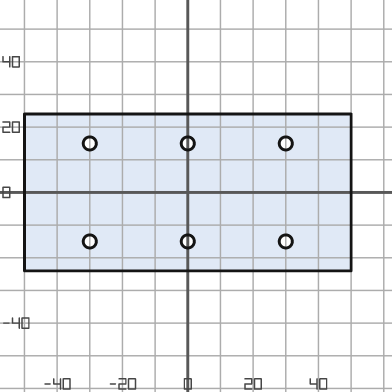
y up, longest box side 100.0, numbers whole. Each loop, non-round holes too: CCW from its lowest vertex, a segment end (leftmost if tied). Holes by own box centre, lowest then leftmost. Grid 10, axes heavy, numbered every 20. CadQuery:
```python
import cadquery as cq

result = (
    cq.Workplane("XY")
    .moveTo(-50.0, -24.0)
    .lineTo(50.0, -24.0)
    .lineTo(50.0, 24.0)
    .lineTo(-50.0, 24.0)
    .close()
    .moveTo(-30.0, -15.0)
    .circle(2.0)
    .moveTo(0.0, -15.0)
    .circle(2.0)
    .moveTo(30.0, -15.0)
    .circle(2.0)
    .moveTo(-30.0, 15.0)
    .circle(2.0)
    .moveTo(0.0, 15.0)
    .circle(2.0)
    .moveTo(30.0, 15.0)
    .circle(2.0)
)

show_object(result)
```